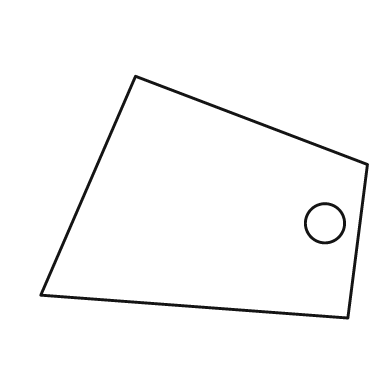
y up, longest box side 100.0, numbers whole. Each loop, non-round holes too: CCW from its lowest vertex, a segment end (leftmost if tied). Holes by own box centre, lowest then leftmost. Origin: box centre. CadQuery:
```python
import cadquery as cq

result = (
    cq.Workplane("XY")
    .moveTo(44.0, -37.0)
    .lineTo(50.0, 10.0)
    .lineTo(-21.0, 37.0)
    .lineTo(-50.0, -30.0)
    .close()
    .moveTo(37.0, -8.0)
    .circle(6.0)
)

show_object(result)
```